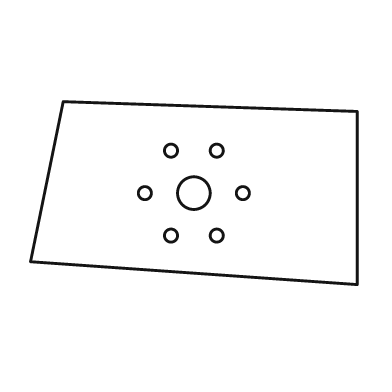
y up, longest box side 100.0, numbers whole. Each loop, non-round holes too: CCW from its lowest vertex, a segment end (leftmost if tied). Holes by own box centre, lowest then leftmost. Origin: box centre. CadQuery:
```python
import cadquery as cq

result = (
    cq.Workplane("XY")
    .moveTo(50.0, -28.0)
    .lineTo(50.0, 25.0)
    .lineTo(-40.0, 28.0)
    .lineTo(-50.0, -21.0)
    .close()
    .moveTo(-7.0, -13.0)
    .circle(2.0)
    .moveTo(7.0, -13.0)
    .circle(2.0)
    .moveTo(-15.0, 0.0)
    .circle(2.0)
    .moveTo(0.0, 0.0)
    .circle(5.0)
    .moveTo(15.0, 0.0)
    .circle(2.0)
    .moveTo(-7.0, 13.0)
    .circle(2.0)
    .moveTo(7.0, 13.0)
    .circle(2.0)
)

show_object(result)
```